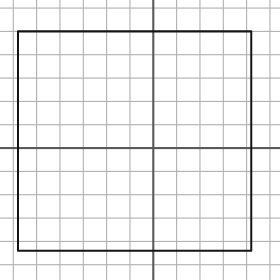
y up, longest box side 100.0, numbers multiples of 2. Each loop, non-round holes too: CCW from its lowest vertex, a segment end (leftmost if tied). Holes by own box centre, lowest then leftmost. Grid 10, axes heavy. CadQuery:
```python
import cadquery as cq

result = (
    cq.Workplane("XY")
    .moveTo(-58.0, -44.0)
    .lineTo(42.0, -44.0)
    .lineTo(42.0, 50.0)
    .lineTo(-58.0, 50.0)
    .close()
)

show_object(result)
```